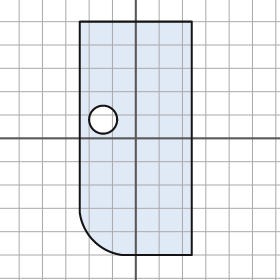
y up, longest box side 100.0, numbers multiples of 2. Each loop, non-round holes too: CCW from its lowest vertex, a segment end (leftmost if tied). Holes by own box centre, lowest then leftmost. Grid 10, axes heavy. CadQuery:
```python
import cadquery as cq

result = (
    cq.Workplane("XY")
    .moveTo(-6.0, -50.0)
    .lineTo(24.0, -50.0)
    .lineTo(24.0, 50.0)
    .lineTo(-24.0, 50.0)
    .lineTo(-24.0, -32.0)
    .threePointArc((-18.0, -44.0), (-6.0, -50.0))
    .close()
    .moveTo(-14.0, 8.0)
    .circle(6.0)
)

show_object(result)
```